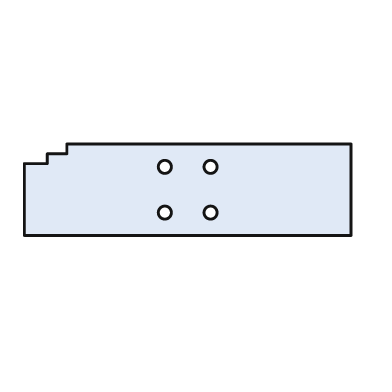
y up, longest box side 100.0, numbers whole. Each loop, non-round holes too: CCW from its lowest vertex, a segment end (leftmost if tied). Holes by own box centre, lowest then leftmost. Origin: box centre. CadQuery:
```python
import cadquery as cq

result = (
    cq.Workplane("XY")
    .moveTo(-50.0, -14.0)
    .lineTo(50.0, -14.0)
    .lineTo(50.0, 14.0)
    .lineTo(-37.0, 14.0)
    .lineTo(-37.0, 11.0)
    .lineTo(-43.0, 11.0)
    .lineTo(-43.0, 8.0)
    .lineTo(-50.0, 8.0)
    .close()
    .moveTo(-7.0, -7.0)
    .circle(2.0)
    .moveTo(7.0, -7.0)
    .circle(2.0)
    .moveTo(-7.0, 7.0)
    .circle(2.0)
    .moveTo(7.0, 7.0)
    .circle(2.0)
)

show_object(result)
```